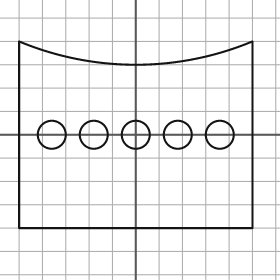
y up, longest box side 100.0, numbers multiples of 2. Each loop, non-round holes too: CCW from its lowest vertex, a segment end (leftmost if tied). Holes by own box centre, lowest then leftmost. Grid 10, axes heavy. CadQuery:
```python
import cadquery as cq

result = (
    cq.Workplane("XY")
    .moveTo(-50.0, -40.0)
    .lineTo(50.0, -40.0)
    .lineTo(50.0, 40.0)
    .threePointArc((0.0, 30.0), (-50.0, 40.0))
    .close()
    .moveTo(-36.0, 0.0)
    .circle(6.0)
    .moveTo(-18.0, 0.0)
    .circle(6.0)
    .moveTo(0.0, 0.0)
    .circle(6.0)
    .moveTo(18.0, 0.0)
    .circle(6.0)
    .moveTo(36.0, 0.0)
    .circle(6.0)
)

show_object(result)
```